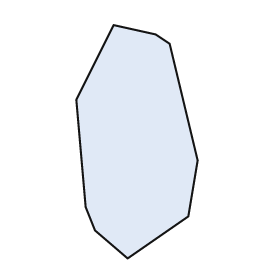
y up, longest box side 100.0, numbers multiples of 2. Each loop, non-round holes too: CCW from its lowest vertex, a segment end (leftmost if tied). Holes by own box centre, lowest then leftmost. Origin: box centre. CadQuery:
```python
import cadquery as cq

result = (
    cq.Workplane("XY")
    .moveTo(-4.0, -50.0)
    .lineTo(22.0, -32.0)
    .lineTo(26.0, -8.0)
    .lineTo(14.0, 42.0)
    .lineTo(8.0, 46.0)
    .lineTo(-10.0, 50.0)
    .lineTo(-26.0, 18.0)
    .lineTo(-22.0, -28.0)
    .lineTo(-18.0, -38.0)
    .close()
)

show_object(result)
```